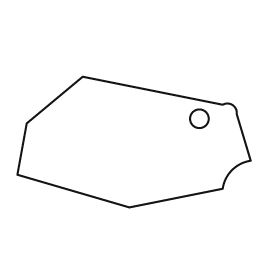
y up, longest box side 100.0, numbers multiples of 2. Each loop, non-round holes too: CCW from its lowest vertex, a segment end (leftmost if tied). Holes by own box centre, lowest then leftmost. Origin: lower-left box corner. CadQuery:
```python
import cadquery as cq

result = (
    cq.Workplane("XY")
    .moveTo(48.0, 0.0)
    .lineTo(88.0, 8.0)
    .threePointArc((92.0, 16.0), (100.0, 20.0))
    .lineTo(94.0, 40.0)
    .threePointArc((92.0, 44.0), (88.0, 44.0))
    .lineTo(28.0, 56.0)
    .lineTo(4.0, 36.0)
    .lineTo(0.0, 14.0)
    .close()
    .moveTo(78.0, 38.0)
    .circle(4.0)
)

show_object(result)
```